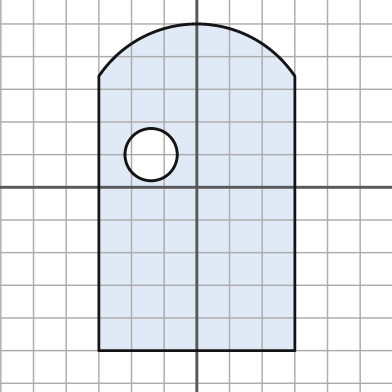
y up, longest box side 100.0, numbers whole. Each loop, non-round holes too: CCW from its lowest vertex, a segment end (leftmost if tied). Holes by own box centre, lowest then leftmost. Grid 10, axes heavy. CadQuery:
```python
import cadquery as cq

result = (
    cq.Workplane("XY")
    .moveTo(-30.0, -50.0)
    .lineTo(30.0, -50.0)
    .lineTo(30.0, 34.0)
    .threePointArc((0.0, 50.0), (-30.0, 34.0))
    .close()
    .moveTo(-14.0, 10.0)
    .circle(8.0)
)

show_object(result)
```